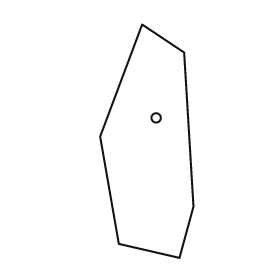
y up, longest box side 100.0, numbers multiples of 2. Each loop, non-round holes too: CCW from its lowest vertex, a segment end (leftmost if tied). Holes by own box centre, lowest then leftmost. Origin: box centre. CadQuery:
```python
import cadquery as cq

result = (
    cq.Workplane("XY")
    .moveTo(14.0, -50.0)
    .lineTo(20.0, -28.0)
    .lineTo(16.0, 38.0)
    .lineTo(-2.0, 50.0)
    .lineTo(-20.0, 2.0)
    .lineTo(-12.0, -44.0)
    .close()
    .moveTo(4.0, 10.0)
    .circle(2.0)
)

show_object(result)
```